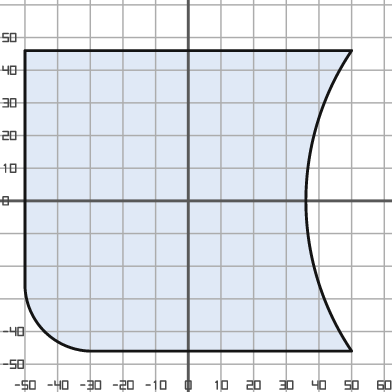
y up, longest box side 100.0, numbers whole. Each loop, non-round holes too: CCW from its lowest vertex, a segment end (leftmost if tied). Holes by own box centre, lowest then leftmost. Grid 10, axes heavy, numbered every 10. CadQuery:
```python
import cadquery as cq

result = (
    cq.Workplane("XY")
    .moveTo(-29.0, -46.0)
    .lineTo(50.0, -46.0)
    .threePointArc((36.0, 0.0), (50.0, 46.0))
    .lineTo(-50.0, 46.0)
    .lineTo(-50.0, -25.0)
    .threePointArc((-44.0, -40.0), (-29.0, -46.0))
    .close()
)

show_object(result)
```